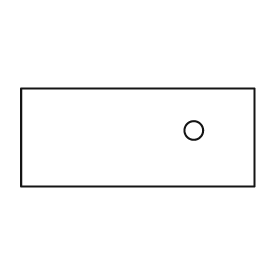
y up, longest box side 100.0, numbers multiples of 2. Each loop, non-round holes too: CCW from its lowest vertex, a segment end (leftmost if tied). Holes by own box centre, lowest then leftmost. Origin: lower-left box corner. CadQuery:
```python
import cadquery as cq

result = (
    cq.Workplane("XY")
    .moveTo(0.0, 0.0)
    .lineTo(100.0, 0.0)
    .lineTo(100.0, 42.0)
    .lineTo(0.0, 42.0)
    .close()
    .moveTo(74.0, 24.0)
    .circle(4.0)
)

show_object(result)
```